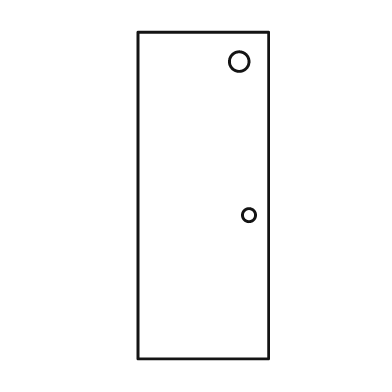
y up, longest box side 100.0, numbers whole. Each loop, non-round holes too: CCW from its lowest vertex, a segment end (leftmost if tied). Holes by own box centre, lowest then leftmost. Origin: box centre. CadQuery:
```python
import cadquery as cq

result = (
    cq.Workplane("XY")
    .moveTo(-20.0, -50.0)
    .lineTo(20.0, -50.0)
    .lineTo(20.0, 50.0)
    .lineTo(-20.0, 50.0)
    .close()
    .moveTo(14.0, -6.0)
    .circle(2.0)
    .moveTo(11.0, 41.0)
    .circle(3.0)
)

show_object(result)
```